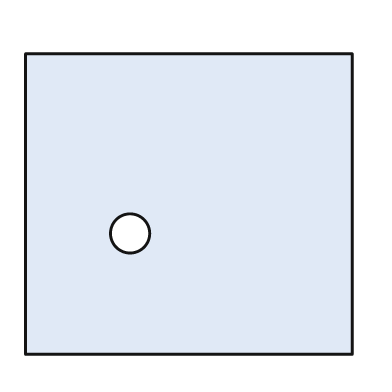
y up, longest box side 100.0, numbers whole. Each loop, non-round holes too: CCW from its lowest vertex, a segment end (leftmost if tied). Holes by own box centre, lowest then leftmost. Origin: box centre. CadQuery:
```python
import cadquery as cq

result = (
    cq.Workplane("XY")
    .moveTo(-50.0, -46.0)
    .lineTo(50.0, -46.0)
    .lineTo(50.0, 46.0)
    .lineTo(-50.0, 46.0)
    .close()
    .moveTo(-18.0, -9.0)
    .circle(6.0)
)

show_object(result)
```